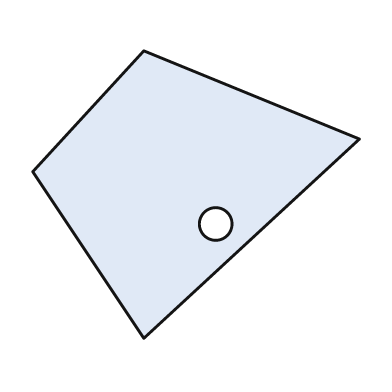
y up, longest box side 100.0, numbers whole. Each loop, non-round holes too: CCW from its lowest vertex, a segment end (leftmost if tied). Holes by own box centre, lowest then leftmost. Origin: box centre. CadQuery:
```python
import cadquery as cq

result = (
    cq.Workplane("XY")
    .moveTo(-16.0, -44.0)
    .lineTo(50.0, 17.0)
    .lineTo(-16.0, 44.0)
    .lineTo(-50.0, 7.0)
    .close()
    .moveTo(6.0, -9.0)
    .circle(5.0)
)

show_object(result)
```